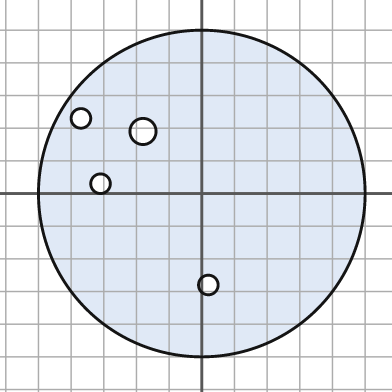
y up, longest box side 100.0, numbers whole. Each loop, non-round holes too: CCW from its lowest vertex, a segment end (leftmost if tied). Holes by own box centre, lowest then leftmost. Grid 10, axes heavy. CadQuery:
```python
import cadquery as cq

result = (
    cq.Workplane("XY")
    .moveTo(0.0, 0.0)
    .circle(50.0)
    .moveTo(2.0, -28.0)
    .circle(3.0)
    .moveTo(-31.0, 3.0)
    .circle(3.0)
    .moveTo(-18.0, 19.0)
    .circle(4.0)
    .moveTo(-37.0, 23.0)
    .circle(3.0)
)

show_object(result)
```